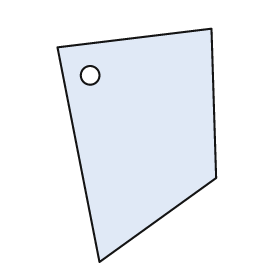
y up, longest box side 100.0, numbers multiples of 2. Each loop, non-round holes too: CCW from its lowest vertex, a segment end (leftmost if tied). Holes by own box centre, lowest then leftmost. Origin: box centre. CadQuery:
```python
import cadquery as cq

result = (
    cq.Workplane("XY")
    .moveTo(-16.0, -50.0)
    .lineTo(34.0, -14.0)
    .lineTo(32.0, 50.0)
    .lineTo(-34.0, 42.0)
    .close()
    .moveTo(-20.0, 30.0)
    .circle(4.0)
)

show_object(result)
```